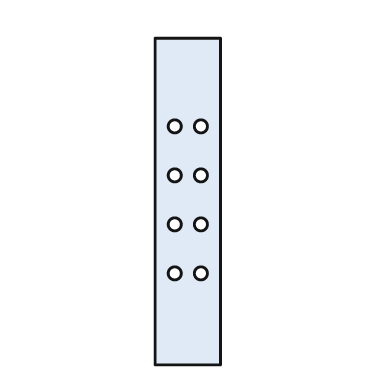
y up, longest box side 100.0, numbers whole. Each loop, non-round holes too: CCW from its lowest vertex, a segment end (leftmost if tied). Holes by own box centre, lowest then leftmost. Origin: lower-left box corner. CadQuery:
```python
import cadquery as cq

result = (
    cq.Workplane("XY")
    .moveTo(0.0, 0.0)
    .lineTo(20.0, 0.0)
    .lineTo(20.0, 100.0)
    .lineTo(0.0, 100.0)
    .close()
    .moveTo(6.0, 28.0)
    .circle(2.0)
    .moveTo(14.0, 28.0)
    .circle(2.0)
    .moveTo(6.0, 43.0)
    .circle(2.0)
    .moveTo(14.0, 43.0)
    .circle(2.0)
    .moveTo(6.0, 58.0)
    .circle(2.0)
    .moveTo(14.0, 58.0)
    .circle(2.0)
    .moveTo(6.0, 73.0)
    .circle(2.0)
    .moveTo(14.0, 73.0)
    .circle(2.0)
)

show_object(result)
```